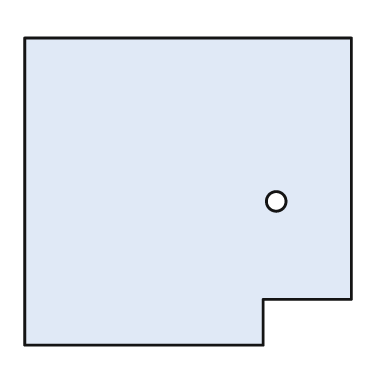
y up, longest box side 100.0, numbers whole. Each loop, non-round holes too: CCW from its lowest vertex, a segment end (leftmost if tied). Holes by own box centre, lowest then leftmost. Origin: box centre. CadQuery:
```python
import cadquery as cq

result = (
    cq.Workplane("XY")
    .moveTo(-50.0, -47.0)
    .lineTo(23.0, -47.0)
    .lineTo(23.0, -33.0)
    .lineTo(50.0, -33.0)
    .lineTo(50.0, 47.0)
    .lineTo(-50.0, 47.0)
    .close()
    .moveTo(27.0, -3.0)
    .circle(3.0)
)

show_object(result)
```